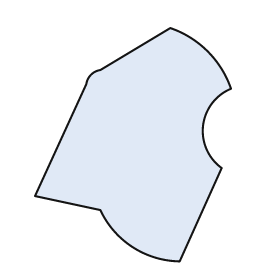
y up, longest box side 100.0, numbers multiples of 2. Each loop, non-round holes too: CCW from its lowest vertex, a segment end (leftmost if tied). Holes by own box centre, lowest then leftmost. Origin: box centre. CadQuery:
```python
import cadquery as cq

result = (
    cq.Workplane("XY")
    .moveTo(20.0, -50.0)
    .lineTo(38.0, -10.0)
    .threePointArc((30.0, 8.0), (42.0, 24.0))
    .threePointArc((32.0, 40.0), (16.0, 50.0))
    .lineTo(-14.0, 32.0)
    .threePointArc((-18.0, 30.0), (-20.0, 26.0))
    .lineTo(-42.0, -22.0)
    .lineTo(-14.0, -28.0)
    .threePointArc((0.0, -44.0), (20.0, -50.0))
    .close()
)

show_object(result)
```